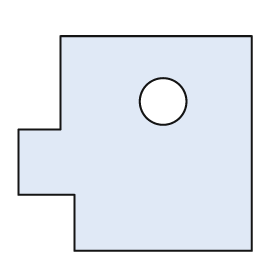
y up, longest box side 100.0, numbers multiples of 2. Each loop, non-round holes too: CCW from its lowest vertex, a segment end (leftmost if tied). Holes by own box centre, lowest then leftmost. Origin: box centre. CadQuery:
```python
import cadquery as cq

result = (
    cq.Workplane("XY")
    .moveTo(-26.0, -46.0)
    .lineTo(50.0, -46.0)
    .lineTo(50.0, 46.0)
    .lineTo(-32.0, 46.0)
    .lineTo(-32.0, 6.0)
    .lineTo(-50.0, 6.0)
    .lineTo(-50.0, -22.0)
    .lineTo(-26.0, -22.0)
    .close()
    .moveTo(12.0, 18.0)
    .circle(10.0)
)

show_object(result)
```